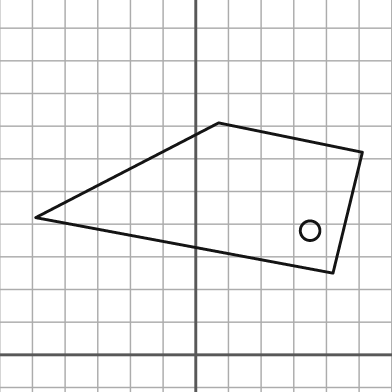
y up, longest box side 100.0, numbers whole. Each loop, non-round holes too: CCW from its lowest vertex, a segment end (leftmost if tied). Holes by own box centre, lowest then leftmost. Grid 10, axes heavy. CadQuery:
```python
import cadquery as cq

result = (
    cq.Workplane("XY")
    .moveTo(42.0, 25.0)
    .lineTo(51.0, 62.0)
    .lineTo(7.0, 71.0)
    .lineTo(-49.0, 42.0)
    .close()
    .moveTo(35.0, 38.0)
    .circle(3.0)
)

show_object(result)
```